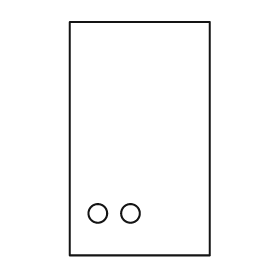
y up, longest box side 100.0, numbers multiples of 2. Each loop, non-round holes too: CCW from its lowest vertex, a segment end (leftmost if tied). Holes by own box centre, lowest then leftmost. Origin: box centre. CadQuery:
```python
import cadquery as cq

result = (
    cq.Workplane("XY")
    .moveTo(-30.0, -50.0)
    .lineTo(30.0, -50.0)
    .lineTo(30.0, 50.0)
    .lineTo(-30.0, 50.0)
    .close()
    .moveTo(-18.0, -32.0)
    .circle(4.0)
    .moveTo(-4.0, -32.0)
    .circle(4.0)
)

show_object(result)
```